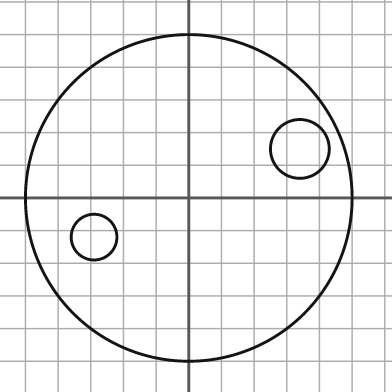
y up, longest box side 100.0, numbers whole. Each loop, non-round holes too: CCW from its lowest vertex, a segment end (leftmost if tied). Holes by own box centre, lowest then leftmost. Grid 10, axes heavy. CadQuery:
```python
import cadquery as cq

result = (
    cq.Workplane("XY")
    .moveTo(0.0, 0.0)
    .circle(50.0)
    .moveTo(-29.0, -12.0)
    .circle(7.0)
    .moveTo(34.0, 15.0)
    .circle(9.0)
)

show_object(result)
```